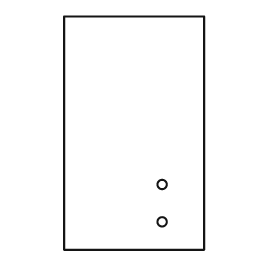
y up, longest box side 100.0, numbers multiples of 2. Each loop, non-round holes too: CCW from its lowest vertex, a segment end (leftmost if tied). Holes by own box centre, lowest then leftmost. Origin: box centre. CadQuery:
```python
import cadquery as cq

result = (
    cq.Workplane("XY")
    .moveTo(-30.0, -50.0)
    .lineTo(30.0, -50.0)
    .lineTo(30.0, 50.0)
    .lineTo(-30.0, 50.0)
    .close()
    .moveTo(12.0, -38.0)
    .circle(2.0)
    .moveTo(12.0, -22.0)
    .circle(2.0)
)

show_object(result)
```